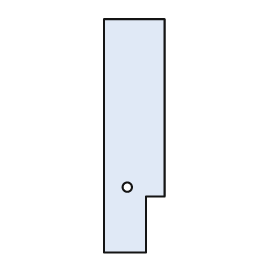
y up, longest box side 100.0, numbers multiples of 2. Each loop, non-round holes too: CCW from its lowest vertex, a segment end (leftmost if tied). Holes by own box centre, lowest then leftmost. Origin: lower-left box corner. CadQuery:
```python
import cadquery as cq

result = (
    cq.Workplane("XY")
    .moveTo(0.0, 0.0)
    .lineTo(18.0, 0.0)
    .lineTo(18.0, 24.0)
    .lineTo(26.0, 24.0)
    .lineTo(26.0, 100.0)
    .lineTo(0.0, 100.0)
    .close()
    .moveTo(10.0, 28.0)
    .circle(2.0)
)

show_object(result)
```